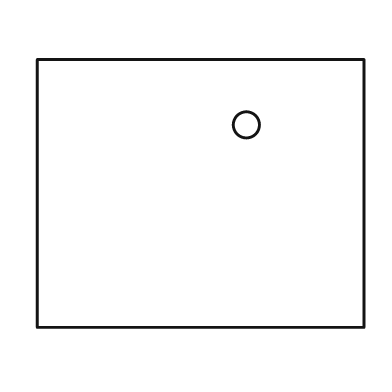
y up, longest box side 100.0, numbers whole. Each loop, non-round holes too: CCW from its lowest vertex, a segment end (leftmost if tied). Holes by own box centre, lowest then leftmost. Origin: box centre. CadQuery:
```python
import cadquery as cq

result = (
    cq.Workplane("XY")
    .moveTo(-50.0, -41.0)
    .lineTo(50.0, -41.0)
    .lineTo(50.0, 41.0)
    .lineTo(-50.0, 41.0)
    .close()
    .moveTo(14.0, 21.0)
    .circle(4.0)
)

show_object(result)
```